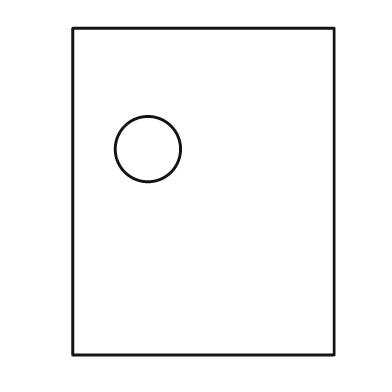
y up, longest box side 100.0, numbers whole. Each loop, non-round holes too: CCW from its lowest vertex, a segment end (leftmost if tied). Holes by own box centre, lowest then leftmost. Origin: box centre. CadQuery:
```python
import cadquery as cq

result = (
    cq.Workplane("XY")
    .moveTo(-40.0, -50.0)
    .lineTo(40.0, -50.0)
    .lineTo(40.0, 50.0)
    .lineTo(-40.0, 50.0)
    .close()
    .moveTo(-17.0, 13.0)
    .circle(10.0)
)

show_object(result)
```